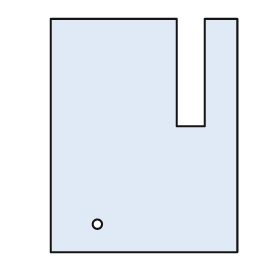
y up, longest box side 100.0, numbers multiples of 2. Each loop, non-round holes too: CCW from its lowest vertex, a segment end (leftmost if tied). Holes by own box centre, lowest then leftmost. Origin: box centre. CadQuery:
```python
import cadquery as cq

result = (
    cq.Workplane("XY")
    .moveTo(-40.0, -50.0)
    .lineTo(40.0, -50.0)
    .lineTo(40.0, 50.0)
    .lineTo(26.0, 50.0)
    .lineTo(26.0, 4.0)
    .lineTo(14.0, 4.0)
    .lineTo(14.0, 50.0)
    .lineTo(-40.0, 50.0)
    .close()
    .moveTo(-20.0, -38.0)
    .circle(2.0)
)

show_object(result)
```